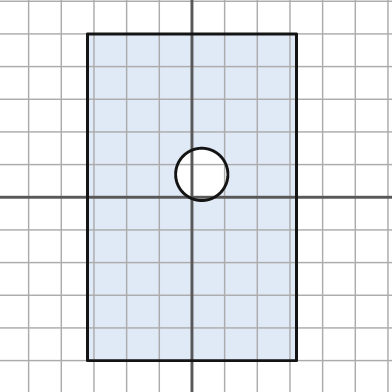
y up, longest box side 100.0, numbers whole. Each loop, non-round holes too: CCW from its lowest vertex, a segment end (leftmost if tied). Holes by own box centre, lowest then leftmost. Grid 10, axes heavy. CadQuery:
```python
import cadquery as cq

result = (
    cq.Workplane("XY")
    .moveTo(-32.0, -50.0)
    .lineTo(32.0, -50.0)
    .lineTo(32.0, 50.0)
    .lineTo(-32.0, 50.0)
    .close()
    .moveTo(3.0, 7.0)
    .circle(8.0)
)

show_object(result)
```